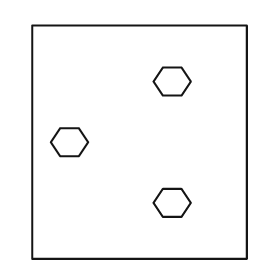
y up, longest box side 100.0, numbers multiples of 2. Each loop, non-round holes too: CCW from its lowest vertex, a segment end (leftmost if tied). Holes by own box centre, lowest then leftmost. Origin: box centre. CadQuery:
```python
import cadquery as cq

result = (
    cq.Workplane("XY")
    .moveTo(-46.0, -50.0)
    .lineTo(46.0, -50.0)
    .lineTo(46.0, 50.0)
    .lineTo(-46.0, 50.0)
    .close()
    .moveTo(10.0, -32.0)
    .lineTo(18.0, -32.0)
    .lineTo(22.0, -26.0)
    .lineTo(18.0, -20.0)
    .lineTo(10.0, -20.0)
    .lineTo(6.0, -26.0)
    .close()
    .moveTo(-34.0, -6.0)
    .lineTo(-26.0, -6.0)
    .lineTo(-22.0, 0.0)
    .lineTo(-26.0, 6.0)
    .lineTo(-34.0, 6.0)
    .lineTo(-38.0, 0.0)
    .close()
    .moveTo(10.0, 20.0)
    .lineTo(18.0, 20.0)
    .lineTo(22.0, 26.0)
    .lineTo(18.0, 32.0)
    .lineTo(10.0, 32.0)
    .lineTo(6.0, 26.0)
    .close()
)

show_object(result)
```